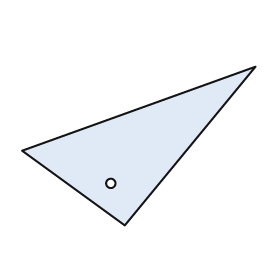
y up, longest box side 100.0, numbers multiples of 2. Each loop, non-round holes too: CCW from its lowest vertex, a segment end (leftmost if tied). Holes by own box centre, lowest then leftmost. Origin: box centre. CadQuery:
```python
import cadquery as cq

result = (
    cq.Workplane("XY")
    .moveTo(-6.0, -34.0)
    .lineTo(50.0, 34.0)
    .lineTo(-50.0, -2.0)
    .close()
    .moveTo(-12.0, -16.0)
    .circle(2.0)
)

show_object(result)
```